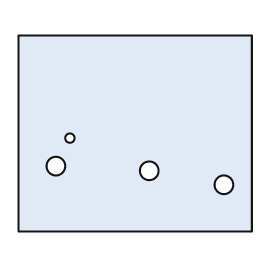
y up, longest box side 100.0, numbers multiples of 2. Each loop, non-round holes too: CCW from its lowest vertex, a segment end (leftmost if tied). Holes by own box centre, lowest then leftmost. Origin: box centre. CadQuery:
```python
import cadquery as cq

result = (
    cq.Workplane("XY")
    .moveTo(-50.0, -42.0)
    .lineTo(50.0, -42.0)
    .lineTo(50.0, 42.0)
    .lineTo(-50.0, 42.0)
    .close()
    .moveTo(38.0, -22.0)
    .circle(4.0)
    .moveTo(6.0, -16.0)
    .circle(4.0)
    .moveTo(-34.0, -14.0)
    .circle(4.0)
    .moveTo(-28.0, -2.0)
    .circle(2.0)
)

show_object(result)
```